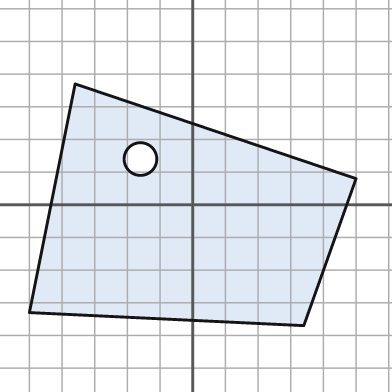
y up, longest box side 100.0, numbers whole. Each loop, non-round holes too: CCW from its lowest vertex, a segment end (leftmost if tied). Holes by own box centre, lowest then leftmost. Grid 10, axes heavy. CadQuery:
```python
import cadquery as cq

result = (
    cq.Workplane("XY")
    .moveTo(34.0, -37.0)
    .lineTo(50.0, 8.0)
    .lineTo(-36.0, 37.0)
    .lineTo(-50.0, -33.0)
    .close()
    .moveTo(-16.0, 14.0)
    .circle(5.0)
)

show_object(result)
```